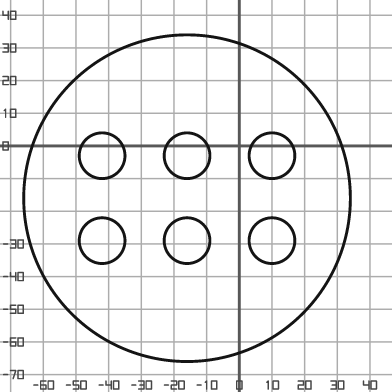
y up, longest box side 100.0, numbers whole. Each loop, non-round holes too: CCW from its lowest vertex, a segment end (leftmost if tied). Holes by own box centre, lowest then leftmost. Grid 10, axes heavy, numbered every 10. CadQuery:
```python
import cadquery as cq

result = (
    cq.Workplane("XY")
    .moveTo(-16.0, -16.0)
    .circle(50.0)
    .moveTo(-42.0, -29.0)
    .circle(7.0)
    .moveTo(-16.0, -29.0)
    .circle(7.0)
    .moveTo(10.0, -29.0)
    .circle(7.0)
    .moveTo(-42.0, -3.0)
    .circle(7.0)
    .moveTo(-16.0, -3.0)
    .circle(7.0)
    .moveTo(10.0, -3.0)
    .circle(7.0)
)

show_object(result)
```